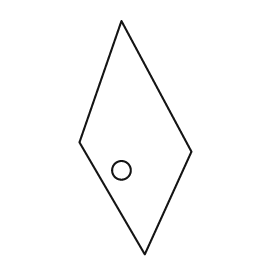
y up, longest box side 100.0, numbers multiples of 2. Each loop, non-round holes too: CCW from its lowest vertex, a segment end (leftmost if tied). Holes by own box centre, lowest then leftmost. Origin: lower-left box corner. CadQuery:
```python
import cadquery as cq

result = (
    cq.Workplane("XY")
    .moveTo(28.0, 0.0)
    .lineTo(48.0, 44.0)
    .lineTo(18.0, 100.0)
    .lineTo(0.0, 48.0)
    .close()
    .moveTo(18.0, 36.0)
    .circle(4.0)
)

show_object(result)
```